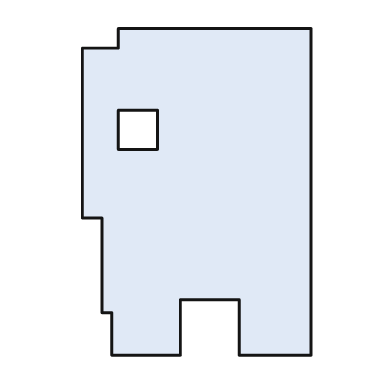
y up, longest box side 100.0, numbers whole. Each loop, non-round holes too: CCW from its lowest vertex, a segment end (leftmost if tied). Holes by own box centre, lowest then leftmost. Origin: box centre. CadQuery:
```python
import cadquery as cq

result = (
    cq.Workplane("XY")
    .moveTo(-26.0, -50.0)
    .lineTo(-5.0, -50.0)
    .lineTo(-5.0, -33.0)
    .lineTo(13.0, -33.0)
    .lineTo(13.0, -50.0)
    .lineTo(35.0, -50.0)
    .lineTo(35.0, 50.0)
    .lineTo(-24.0, 50.0)
    .lineTo(-24.0, 44.0)
    .lineTo(-35.0, 44.0)
    .lineTo(-35.0, -8.0)
    .lineTo(-29.0, -8.0)
    .lineTo(-29.0, -37.0)
    .lineTo(-26.0, -37.0)
    .close()
    .moveTo(-24.0, 13.0)
    .lineTo(-12.0, 13.0)
    .lineTo(-12.0, 25.0)
    .lineTo(-24.0, 25.0)
    .close()
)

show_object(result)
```